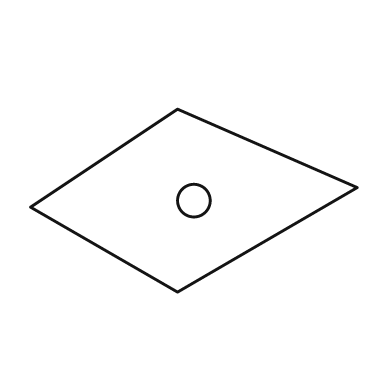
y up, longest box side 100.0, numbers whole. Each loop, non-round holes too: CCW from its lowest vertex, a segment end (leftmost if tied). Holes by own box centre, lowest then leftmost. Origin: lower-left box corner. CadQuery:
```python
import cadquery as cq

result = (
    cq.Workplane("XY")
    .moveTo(45.0, 0.0)
    .lineTo(100.0, 32.0)
    .lineTo(45.0, 56.0)
    .lineTo(0.0, 26.0)
    .close()
    .moveTo(50.0, 28.0)
    .circle(5.0)
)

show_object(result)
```